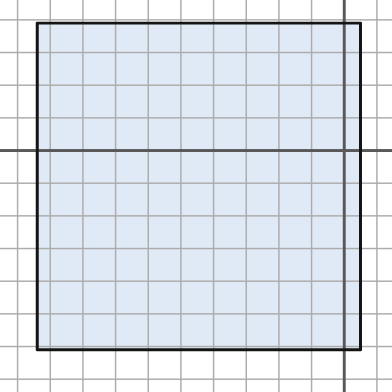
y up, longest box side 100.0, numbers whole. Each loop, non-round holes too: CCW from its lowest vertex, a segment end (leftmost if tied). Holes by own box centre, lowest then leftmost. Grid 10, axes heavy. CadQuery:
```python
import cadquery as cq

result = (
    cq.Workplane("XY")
    .moveTo(-94.0, -61.0)
    .lineTo(5.0, -61.0)
    .lineTo(5.0, 39.0)
    .lineTo(-94.0, 39.0)
    .close()
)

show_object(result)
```